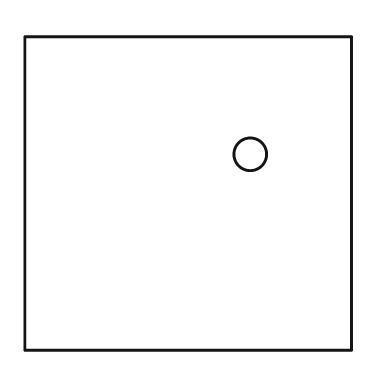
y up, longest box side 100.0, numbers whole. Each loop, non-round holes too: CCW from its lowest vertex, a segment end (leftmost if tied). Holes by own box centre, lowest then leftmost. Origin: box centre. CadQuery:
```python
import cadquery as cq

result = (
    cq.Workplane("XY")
    .moveTo(-50.0, -48.0)
    .lineTo(50.0, -48.0)
    .lineTo(50.0, 48.0)
    .lineTo(-50.0, 48.0)
    .close()
    .moveTo(19.0, 12.0)
    .circle(5.0)
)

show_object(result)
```